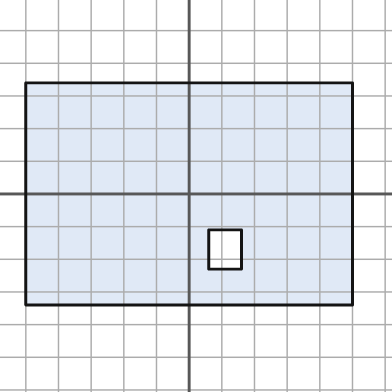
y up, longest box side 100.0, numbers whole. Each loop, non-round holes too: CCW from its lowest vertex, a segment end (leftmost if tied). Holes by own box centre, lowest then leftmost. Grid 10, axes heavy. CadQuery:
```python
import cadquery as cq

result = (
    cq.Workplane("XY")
    .moveTo(-50.0, -34.0)
    .lineTo(50.0, -34.0)
    .lineTo(50.0, 34.0)
    .lineTo(-50.0, 34.0)
    .close()
    .moveTo(6.0, -23.0)
    .lineTo(16.0, -23.0)
    .lineTo(16.0, -11.0)
    .lineTo(6.0, -11.0)
    .close()
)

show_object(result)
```